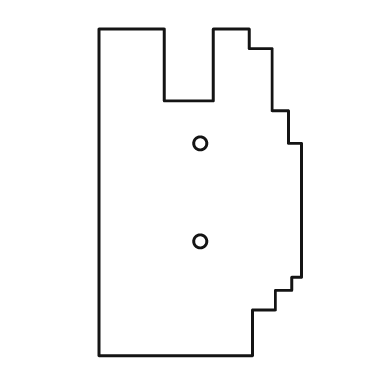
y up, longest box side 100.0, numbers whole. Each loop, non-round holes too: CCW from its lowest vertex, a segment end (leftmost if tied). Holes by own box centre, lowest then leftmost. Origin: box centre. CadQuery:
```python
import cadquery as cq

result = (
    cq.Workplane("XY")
    .moveTo(-31.0, -50.0)
    .lineTo(16.0, -50.0)
    .lineTo(16.0, -36.0)
    .lineTo(23.0, -36.0)
    .lineTo(23.0, -30.0)
    .lineTo(28.0, -30.0)
    .lineTo(28.0, -26.0)
    .lineTo(31.0, -26.0)
    .lineTo(31.0, 15.0)
    .lineTo(27.0, 15.0)
    .lineTo(27.0, 25.0)
    .lineTo(22.0, 25.0)
    .lineTo(22.0, 44.0)
    .lineTo(15.0, 44.0)
    .lineTo(15.0, 50.0)
    .lineTo(4.0, 50.0)
    .lineTo(4.0, 28.0)
    .lineTo(-11.0, 28.0)
    .lineTo(-11.0, 50.0)
    .lineTo(-31.0, 50.0)
    .close()
    .moveTo(0.0, -15.0)
    .circle(2.0)
    .moveTo(0.0, 15.0)
    .circle(2.0)
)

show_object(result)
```